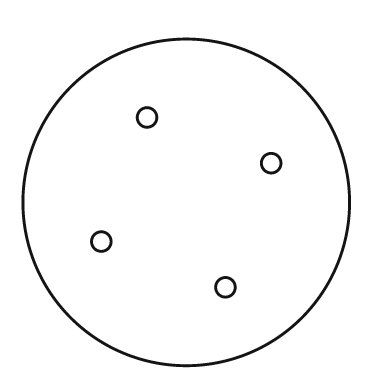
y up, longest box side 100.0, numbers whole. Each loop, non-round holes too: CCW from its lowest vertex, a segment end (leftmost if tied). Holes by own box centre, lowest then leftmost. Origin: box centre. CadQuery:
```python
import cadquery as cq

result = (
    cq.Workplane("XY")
    .moveTo(0.0, 0.0)
    .circle(50.0)
    .moveTo(12.0, -26.0)
    .circle(3.0)
    .moveTo(-26.0, -12.0)
    .circle(3.0)
    .moveTo(26.0, 12.0)
    .circle(3.0)
    .moveTo(-12.0, 26.0)
    .circle(3.0)
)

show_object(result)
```